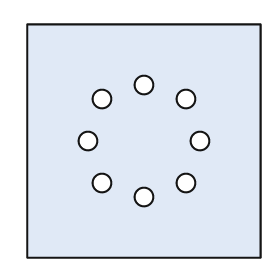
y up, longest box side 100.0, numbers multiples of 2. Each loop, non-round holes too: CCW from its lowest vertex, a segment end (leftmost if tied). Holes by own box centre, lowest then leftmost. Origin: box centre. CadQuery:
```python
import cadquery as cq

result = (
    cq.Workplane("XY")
    .moveTo(-50.0, -50.0)
    .lineTo(50.0, -50.0)
    .lineTo(50.0, 50.0)
    .lineTo(-50.0, 50.0)
    .close()
    .moveTo(0.0, -24.0)
    .circle(4.0)
    .moveTo(-18.0, -18.0)
    .circle(4.0)
    .moveTo(18.0, -18.0)
    .circle(4.0)
    .moveTo(-24.0, 0.0)
    .circle(4.0)
    .moveTo(24.0, 0.0)
    .circle(4.0)
    .moveTo(-18.0, 18.0)
    .circle(4.0)
    .moveTo(18.0, 18.0)
    .circle(4.0)
    .moveTo(0.0, 24.0)
    .circle(4.0)
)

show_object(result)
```